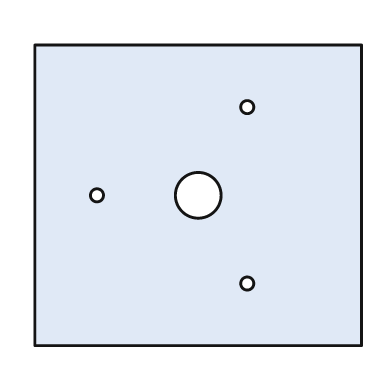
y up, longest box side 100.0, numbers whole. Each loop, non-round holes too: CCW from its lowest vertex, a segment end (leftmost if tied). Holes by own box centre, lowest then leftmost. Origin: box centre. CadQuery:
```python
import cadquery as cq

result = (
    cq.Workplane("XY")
    .moveTo(-50.0, -46.0)
    .lineTo(50.0, -46.0)
    .lineTo(50.0, 46.0)
    .lineTo(-50.0, 46.0)
    .close()
    .moveTo(15.0, -27.0)
    .circle(2.0)
    .moveTo(-31.0, 0.0)
    .circle(2.0)
    .moveTo(0.0, 0.0)
    .circle(7.0)
    .moveTo(15.0, 27.0)
    .circle(2.0)
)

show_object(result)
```